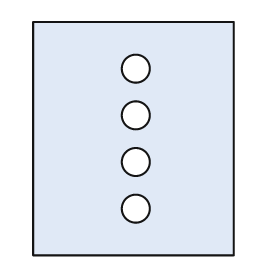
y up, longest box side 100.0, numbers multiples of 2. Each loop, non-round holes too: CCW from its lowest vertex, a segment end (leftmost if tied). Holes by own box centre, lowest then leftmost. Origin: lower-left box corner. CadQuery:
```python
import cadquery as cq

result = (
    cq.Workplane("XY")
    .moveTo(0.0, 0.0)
    .lineTo(86.0, 0.0)
    .lineTo(86.0, 100.0)
    .lineTo(0.0, 100.0)
    .close()
    .moveTo(44.0, 20.0)
    .circle(6.0)
    .moveTo(44.0, 40.0)
    .circle(6.0)
    .moveTo(44.0, 60.0)
    .circle(6.0)
    .moveTo(44.0, 80.0)
    .circle(6.0)
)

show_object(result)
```